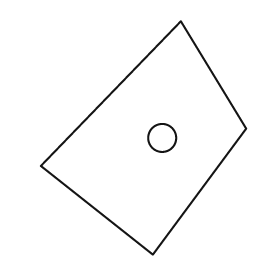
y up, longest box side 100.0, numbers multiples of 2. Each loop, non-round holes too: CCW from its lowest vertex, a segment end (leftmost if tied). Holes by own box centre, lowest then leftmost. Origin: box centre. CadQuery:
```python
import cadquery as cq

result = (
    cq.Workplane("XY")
    .moveTo(4.0, -50.0)
    .lineTo(44.0, 4.0)
    .lineTo(16.0, 50.0)
    .lineTo(-44.0, -12.0)
    .close()
    .moveTo(8.0, 0.0)
    .circle(6.0)
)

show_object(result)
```